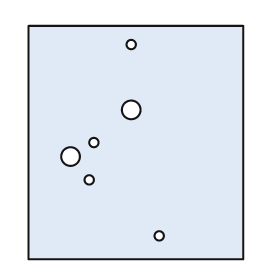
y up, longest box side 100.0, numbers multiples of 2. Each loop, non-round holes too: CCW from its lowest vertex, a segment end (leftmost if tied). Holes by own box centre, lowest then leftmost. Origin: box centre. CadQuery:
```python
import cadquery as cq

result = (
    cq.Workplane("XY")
    .moveTo(-46.0, -50.0)
    .lineTo(46.0, -50.0)
    .lineTo(46.0, 50.0)
    .lineTo(-46.0, 50.0)
    .close()
    .moveTo(10.0, -40.0)
    .circle(2.0)
    .moveTo(-20.0, -16.0)
    .circle(2.0)
    .moveTo(-28.0, -6.0)
    .circle(4.0)
    .moveTo(-18.0, 0.0)
    .circle(2.0)
    .moveTo(-2.0, 14.0)
    .circle(4.0)
    .moveTo(-2.0, 42.0)
    .circle(2.0)
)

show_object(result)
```